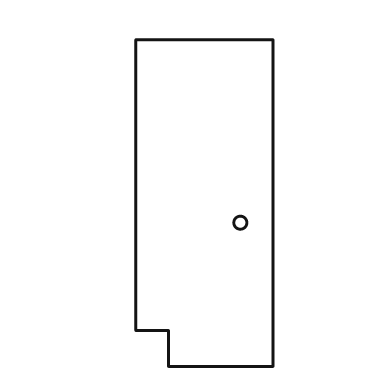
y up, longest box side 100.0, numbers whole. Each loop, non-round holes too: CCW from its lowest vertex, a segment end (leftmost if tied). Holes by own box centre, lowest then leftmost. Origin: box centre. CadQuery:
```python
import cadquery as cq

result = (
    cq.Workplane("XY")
    .moveTo(-11.0, -50.0)
    .lineTo(21.0, -50.0)
    .lineTo(21.0, 50.0)
    .lineTo(-21.0, 50.0)
    .lineTo(-21.0, -39.0)
    .lineTo(-11.0, -39.0)
    .close()
    .moveTo(11.0, -6.0)
    .circle(2.0)
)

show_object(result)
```